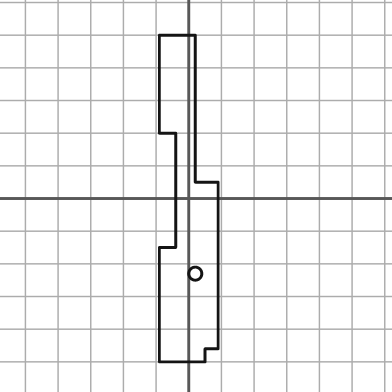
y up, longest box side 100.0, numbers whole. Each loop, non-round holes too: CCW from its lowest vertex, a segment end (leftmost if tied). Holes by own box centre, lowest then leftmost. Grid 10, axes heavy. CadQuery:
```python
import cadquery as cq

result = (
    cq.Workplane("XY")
    .moveTo(-9.0, -50.0)
    .lineTo(5.0, -50.0)
    .lineTo(5.0, -46.0)
    .lineTo(9.0, -46.0)
    .lineTo(9.0, 5.0)
    .lineTo(2.0, 5.0)
    .lineTo(2.0, 50.0)
    .lineTo(-9.0, 50.0)
    .lineTo(-9.0, 20.0)
    .lineTo(-4.0, 20.0)
    .lineTo(-4.0, -15.0)
    .lineTo(-9.0, -15.0)
    .close()
    .moveTo(2.0, -23.0)
    .circle(2.0)
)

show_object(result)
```